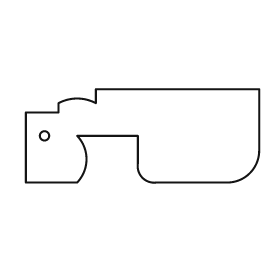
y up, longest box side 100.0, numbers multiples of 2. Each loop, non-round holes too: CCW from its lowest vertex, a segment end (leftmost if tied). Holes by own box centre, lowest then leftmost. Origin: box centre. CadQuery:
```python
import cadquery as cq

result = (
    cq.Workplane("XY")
    .moveTo(-50.0, -20.0)
    .lineTo(-28.0, -20.0)
    .threePointArc((-24.0, -10.0), (-28.0, 0.0))
    .lineTo(-2.0, 0.0)
    .lineTo(-2.0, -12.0)
    .threePointArc((0.0, -18.0), (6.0, -20.0))
    .lineTo(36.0, -20.0)
    .threePointArc((46.0, -16.0), (50.0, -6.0))
    .lineTo(50.0, 20.0)
    .lineTo(-20.0, 20.0)
    .lineTo(-20.0, 14.0)
    .threePointArc((-28.0, 16.0), (-36.0, 14.0))
    .lineTo(-36.0, 10.0)
    .lineTo(-50.0, 10.0)
    .close()
    .moveTo(-42.0, 0.0)
    .circle(2.0)
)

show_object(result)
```